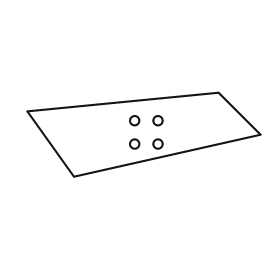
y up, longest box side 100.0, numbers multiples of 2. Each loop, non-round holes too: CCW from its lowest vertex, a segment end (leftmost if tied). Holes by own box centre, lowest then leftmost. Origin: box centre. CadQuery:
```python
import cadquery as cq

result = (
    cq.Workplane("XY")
    .moveTo(-30.0, -18.0)
    .lineTo(50.0, 0.0)
    .lineTo(32.0, 18.0)
    .lineTo(-50.0, 10.0)
    .close()
    .moveTo(-4.0, -4.0)
    .circle(2.0)
    .moveTo(6.0, -4.0)
    .circle(2.0)
    .moveTo(-4.0, 6.0)
    .circle(2.0)
    .moveTo(6.0, 6.0)
    .circle(2.0)
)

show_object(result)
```